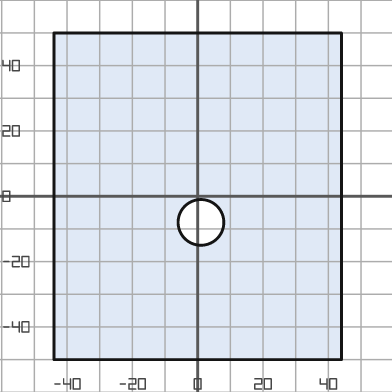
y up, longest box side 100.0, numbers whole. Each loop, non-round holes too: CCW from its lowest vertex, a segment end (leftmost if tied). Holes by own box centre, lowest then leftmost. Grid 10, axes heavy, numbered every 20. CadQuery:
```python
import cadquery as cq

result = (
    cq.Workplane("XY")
    .moveTo(-44.0, -50.0)
    .lineTo(44.0, -50.0)
    .lineTo(44.0, 50.0)
    .lineTo(-44.0, 50.0)
    .close()
    .moveTo(1.0, -8.0)
    .circle(7.0)
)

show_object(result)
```